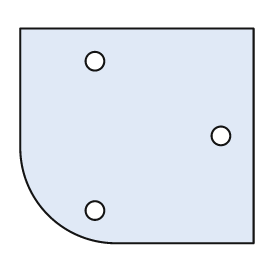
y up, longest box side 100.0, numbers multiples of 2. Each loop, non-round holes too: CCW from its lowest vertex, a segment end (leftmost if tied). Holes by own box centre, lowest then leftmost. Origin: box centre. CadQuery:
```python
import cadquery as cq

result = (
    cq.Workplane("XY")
    .moveTo(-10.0, -46.0)
    .lineTo(50.0, -46.0)
    .lineTo(50.0, 46.0)
    .lineTo(-50.0, 46.0)
    .lineTo(-50.0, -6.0)
    .threePointArc((-38.0, -34.0), (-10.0, -46.0))
    .close()
    .moveTo(-18.0, -32.0)
    .circle(4.0)
    .moveTo(36.0, 0.0)
    .circle(4.0)
    .moveTo(-18.0, 32.0)
    .circle(4.0)
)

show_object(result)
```